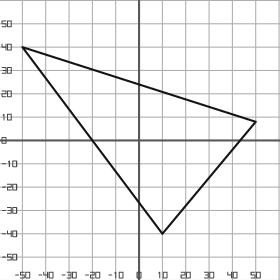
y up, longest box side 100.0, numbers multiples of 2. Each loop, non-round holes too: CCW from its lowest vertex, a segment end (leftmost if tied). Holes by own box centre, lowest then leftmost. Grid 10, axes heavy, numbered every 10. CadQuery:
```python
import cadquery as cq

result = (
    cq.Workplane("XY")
    .moveTo(10.0, -40.0)
    .lineTo(50.0, 8.0)
    .lineTo(-50.0, 40.0)
    .close()
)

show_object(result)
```